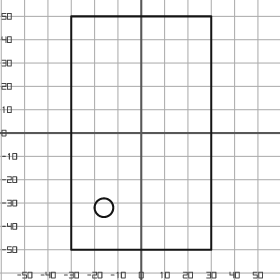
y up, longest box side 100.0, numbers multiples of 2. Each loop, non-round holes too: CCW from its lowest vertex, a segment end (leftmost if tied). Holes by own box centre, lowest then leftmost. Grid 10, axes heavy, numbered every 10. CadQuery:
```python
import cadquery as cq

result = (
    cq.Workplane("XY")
    .moveTo(-30.0, -50.0)
    .lineTo(30.0, -50.0)
    .lineTo(30.0, 50.0)
    .lineTo(-30.0, 50.0)
    .close()
    .moveTo(-16.0, -32.0)
    .circle(4.0)
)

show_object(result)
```